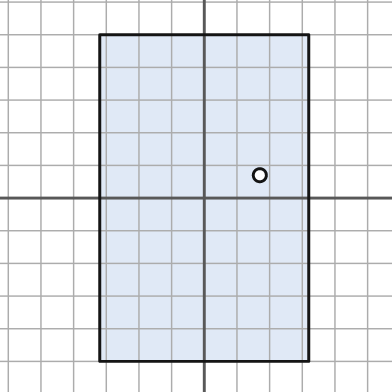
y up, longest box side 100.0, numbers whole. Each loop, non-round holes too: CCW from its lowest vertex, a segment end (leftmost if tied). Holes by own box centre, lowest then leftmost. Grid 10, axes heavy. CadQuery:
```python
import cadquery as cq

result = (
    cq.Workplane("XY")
    .moveTo(-32.0, -50.0)
    .lineTo(32.0, -50.0)
    .lineTo(32.0, 50.0)
    .lineTo(-32.0, 50.0)
    .close()
    .moveTo(17.0, 7.0)
    .circle(2.0)
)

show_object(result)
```